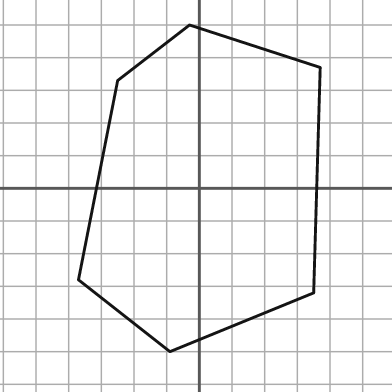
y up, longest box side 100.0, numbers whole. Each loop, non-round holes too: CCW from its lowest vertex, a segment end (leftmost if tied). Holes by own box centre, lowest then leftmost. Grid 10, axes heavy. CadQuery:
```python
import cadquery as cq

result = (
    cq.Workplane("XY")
    .moveTo(-9.0, -50.0)
    .lineTo(35.0, -32.0)
    .lineTo(37.0, 37.0)
    .lineTo(-3.0, 50.0)
    .lineTo(-25.0, 33.0)
    .lineTo(-37.0, -28.0)
    .close()
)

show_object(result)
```